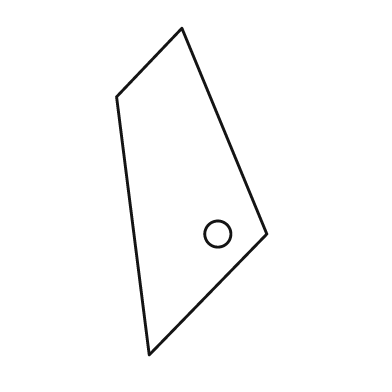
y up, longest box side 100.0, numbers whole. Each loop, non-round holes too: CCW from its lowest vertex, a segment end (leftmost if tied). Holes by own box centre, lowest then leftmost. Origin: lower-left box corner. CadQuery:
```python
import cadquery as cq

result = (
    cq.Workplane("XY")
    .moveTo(10.0, 0.0)
    .lineTo(46.0, 37.0)
    .lineTo(20.0, 100.0)
    .lineTo(0.0, 79.0)
    .close()
    .moveTo(31.0, 37.0)
    .circle(4.0)
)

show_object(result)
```